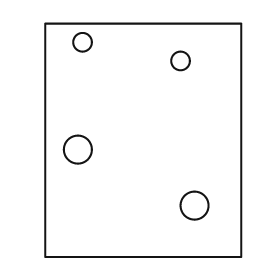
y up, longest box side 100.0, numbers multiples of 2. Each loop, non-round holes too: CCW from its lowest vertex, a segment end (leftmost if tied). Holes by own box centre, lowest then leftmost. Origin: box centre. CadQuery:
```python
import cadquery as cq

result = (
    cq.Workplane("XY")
    .moveTo(-42.0, -50.0)
    .lineTo(42.0, -50.0)
    .lineTo(42.0, 50.0)
    .lineTo(-42.0, 50.0)
    .close()
    .moveTo(22.0, -28.0)
    .circle(6.0)
    .moveTo(-28.0, -4.0)
    .circle(6.0)
    .moveTo(16.0, 34.0)
    .circle(4.0)
    .moveTo(-26.0, 42.0)
    .circle(4.0)
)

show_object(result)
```